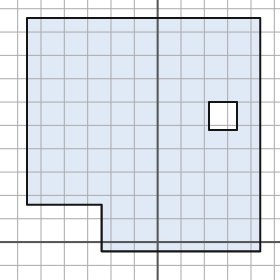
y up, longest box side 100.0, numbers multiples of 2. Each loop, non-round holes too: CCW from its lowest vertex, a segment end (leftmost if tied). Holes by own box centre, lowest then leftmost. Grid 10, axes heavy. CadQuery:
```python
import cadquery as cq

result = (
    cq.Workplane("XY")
    .moveTo(-24.0, -4.0)
    .lineTo(44.0, -4.0)
    .lineTo(44.0, 96.0)
    .lineTo(-56.0, 96.0)
    .lineTo(-56.0, 16.0)
    .lineTo(-24.0, 16.0)
    .close()
    .moveTo(22.0, 48.0)
    .lineTo(34.0, 48.0)
    .lineTo(34.0, 60.0)
    .lineTo(22.0, 60.0)
    .close()
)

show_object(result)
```